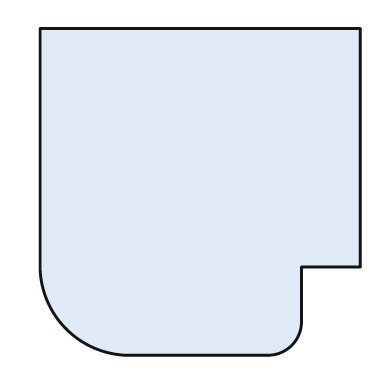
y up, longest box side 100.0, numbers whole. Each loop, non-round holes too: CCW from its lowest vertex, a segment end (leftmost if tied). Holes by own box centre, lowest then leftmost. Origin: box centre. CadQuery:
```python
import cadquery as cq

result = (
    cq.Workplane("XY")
    .moveTo(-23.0, -50.0)
    .lineTo(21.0, -50.0)
    .threePointArc((28.0, -47.0), (31.0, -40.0))
    .lineTo(31.0, -23.0)
    .lineTo(49.0, -23.0)
    .lineTo(49.0, 50.0)
    .lineTo(-49.0, 50.0)
    .lineTo(-49.0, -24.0)
    .threePointArc((-41.0, -42.0), (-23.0, -50.0))
    .close()
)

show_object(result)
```